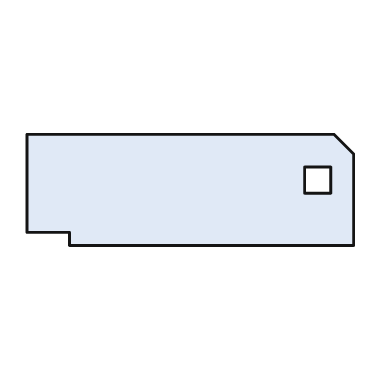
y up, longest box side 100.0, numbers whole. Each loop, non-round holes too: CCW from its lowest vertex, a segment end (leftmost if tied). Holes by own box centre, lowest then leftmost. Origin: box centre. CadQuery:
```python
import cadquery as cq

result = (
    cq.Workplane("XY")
    .moveTo(-37.0, -17.0)
    .lineTo(50.0, -17.0)
    .lineTo(50.0, 11.0)
    .lineTo(44.0, 17.0)
    .lineTo(-50.0, 17.0)
    .lineTo(-50.0, -13.0)
    .lineTo(-37.0, -13.0)
    .close()
    .moveTo(35.0, -1.0)
    .lineTo(43.0, -1.0)
    .lineTo(43.0, 7.0)
    .lineTo(35.0, 7.0)
    .close()
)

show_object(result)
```